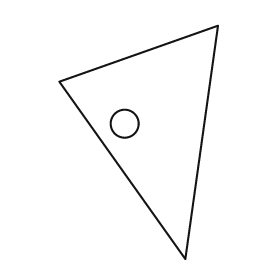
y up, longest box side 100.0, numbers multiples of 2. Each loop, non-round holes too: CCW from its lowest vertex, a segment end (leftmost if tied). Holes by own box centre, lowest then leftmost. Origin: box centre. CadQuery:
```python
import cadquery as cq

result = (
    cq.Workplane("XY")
    .moveTo(20.0, -50.0)
    .lineTo(34.0, 50.0)
    .lineTo(-34.0, 26.0)
    .close()
    .moveTo(-6.0, 8.0)
    .circle(6.0)
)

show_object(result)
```